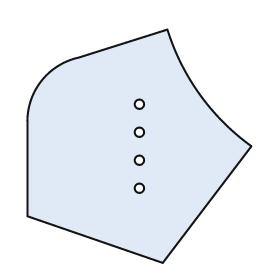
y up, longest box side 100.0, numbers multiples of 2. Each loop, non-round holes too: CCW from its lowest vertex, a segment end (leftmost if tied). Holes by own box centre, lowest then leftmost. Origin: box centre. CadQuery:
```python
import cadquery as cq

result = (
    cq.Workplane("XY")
    .moveTo(10.0, -50.0)
    .lineTo(48.0, 0.0)
    .threePointArc((26.0, 22.0), (12.0, 50.0))
    .lineTo(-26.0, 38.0)
    .threePointArc((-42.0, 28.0), (-48.0, 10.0))
    .lineTo(-48.0, -30.0)
    .close()
    .moveTo(0.0, -18.0)
    .circle(2.0)
    .moveTo(0.0, -6.0)
    .circle(2.0)
    .moveTo(0.0, 6.0)
    .circle(2.0)
    .moveTo(0.0, 18.0)
    .circle(2.0)
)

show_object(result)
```